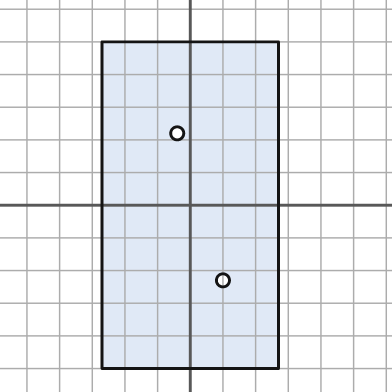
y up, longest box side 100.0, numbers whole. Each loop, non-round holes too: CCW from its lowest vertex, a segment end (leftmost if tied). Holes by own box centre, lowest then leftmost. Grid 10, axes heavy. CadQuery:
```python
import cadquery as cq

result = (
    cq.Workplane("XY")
    .moveTo(-27.0, -50.0)
    .lineTo(27.0, -50.0)
    .lineTo(27.0, 50.0)
    .lineTo(-27.0, 50.0)
    .close()
    .moveTo(10.0, -23.0)
    .circle(2.0)
    .moveTo(-4.0, 22.0)
    .circle(2.0)
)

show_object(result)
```